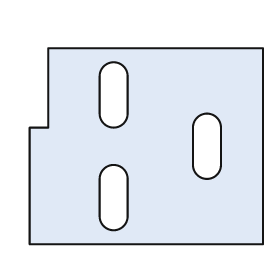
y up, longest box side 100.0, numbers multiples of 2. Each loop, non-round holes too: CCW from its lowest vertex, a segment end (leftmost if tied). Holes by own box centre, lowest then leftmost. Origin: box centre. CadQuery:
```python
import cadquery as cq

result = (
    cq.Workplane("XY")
    .moveTo(-50.0, -42.0)
    .lineTo(50.0, -42.0)
    .lineTo(50.0, 42.0)
    .lineTo(-42.0, 42.0)
    .lineTo(-42.0, 8.0)
    .lineTo(-50.0, 8.0)
    .close()
    .moveTo(-20.0, -30.0)
    .threePointArc((-14.0, -36.0), (-8.0, -30.0))
    .lineTo(-8.0, -14.0)
    .threePointArc((-14.0, -8.0), (-20.0, -14.0))
    .close()
    .moveTo(20.0, -8.0)
    .threePointArc((26.0, -14.0), (32.0, -8.0))
    .lineTo(32.0, 8.0)
    .threePointArc((26.0, 14.0), (20.0, 8.0))
    .close()
    .moveTo(-20.0, 14.0)
    .threePointArc((-14.0, 8.0), (-8.0, 14.0))
    .lineTo(-8.0, 30.0)
    .threePointArc((-14.0, 36.0), (-20.0, 30.0))
    .close()
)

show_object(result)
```